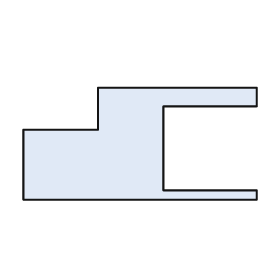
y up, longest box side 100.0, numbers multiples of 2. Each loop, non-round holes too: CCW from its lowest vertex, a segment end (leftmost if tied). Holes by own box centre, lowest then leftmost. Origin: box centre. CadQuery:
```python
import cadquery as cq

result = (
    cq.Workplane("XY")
    .moveTo(-50.0, -24.0)
    .lineTo(50.0, -24.0)
    .lineTo(50.0, -20.0)
    .lineTo(10.0, -20.0)
    .lineTo(10.0, 16.0)
    .lineTo(50.0, 16.0)
    .lineTo(50.0, 24.0)
    .lineTo(-18.0, 24.0)
    .lineTo(-18.0, 6.0)
    .lineTo(-50.0, 6.0)
    .close()
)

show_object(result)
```